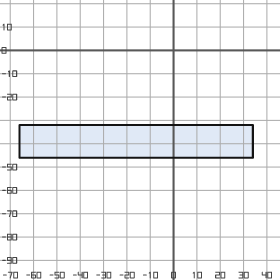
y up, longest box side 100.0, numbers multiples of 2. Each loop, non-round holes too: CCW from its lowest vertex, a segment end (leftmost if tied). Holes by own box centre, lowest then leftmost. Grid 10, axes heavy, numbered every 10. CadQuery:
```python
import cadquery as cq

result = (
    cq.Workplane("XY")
    .moveTo(-66.0, -46.0)
    .lineTo(34.0, -46.0)
    .lineTo(34.0, -32.0)
    .lineTo(-66.0, -32.0)
    .close()
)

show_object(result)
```